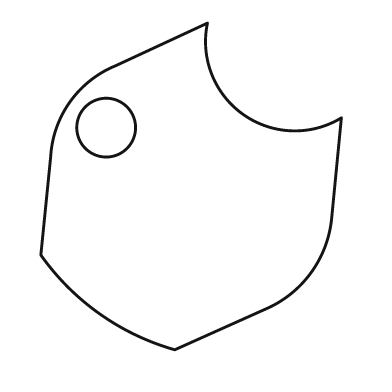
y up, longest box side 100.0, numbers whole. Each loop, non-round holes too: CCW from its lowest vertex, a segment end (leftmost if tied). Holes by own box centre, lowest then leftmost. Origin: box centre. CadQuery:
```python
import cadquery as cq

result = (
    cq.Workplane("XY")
    .moveTo(-5.0, -50.0)
    .lineTo(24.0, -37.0)
    .threePointArc((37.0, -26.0), (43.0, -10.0))
    .lineTo(46.0, 21.0)
    .threePointArc((16.0, 22.0), (5.0, 50.0))
    .lineTo(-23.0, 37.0)
    .threePointArc((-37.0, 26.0), (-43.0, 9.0))
    .lineTo(-46.0, -21.0)
    .threePointArc((-28.0, -39.0), (-5.0, -50.0))
    .close()
    .moveTo(-26.0, 18.0)
    .circle(9.0)
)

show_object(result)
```